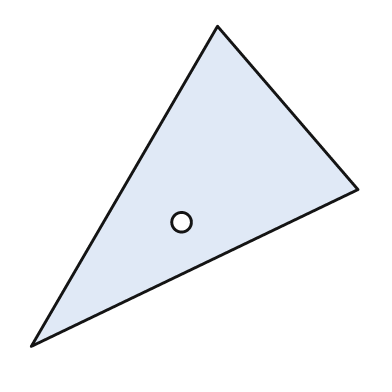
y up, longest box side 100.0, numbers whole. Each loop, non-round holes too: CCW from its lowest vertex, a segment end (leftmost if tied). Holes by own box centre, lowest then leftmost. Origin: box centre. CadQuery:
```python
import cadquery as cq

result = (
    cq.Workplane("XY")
    .moveTo(-50.0, -49.0)
    .lineTo(50.0, -1.0)
    .lineTo(7.0, 49.0)
    .close()
    .moveTo(-4.0, -11.0)
    .circle(3.0)
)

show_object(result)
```